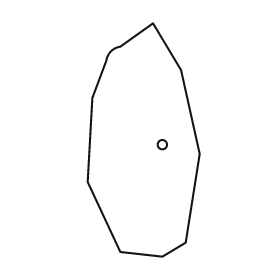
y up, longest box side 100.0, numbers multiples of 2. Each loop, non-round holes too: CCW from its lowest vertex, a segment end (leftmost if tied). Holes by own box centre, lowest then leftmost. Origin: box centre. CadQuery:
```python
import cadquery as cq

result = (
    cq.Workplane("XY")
    .moveTo(8.0, -50.0)
    .lineTo(18.0, -44.0)
    .lineTo(24.0, -6.0)
    .lineTo(16.0, 30.0)
    .lineTo(4.0, 50.0)
    .lineTo(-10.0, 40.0)
    .threePointArc((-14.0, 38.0), (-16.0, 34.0))
    .lineTo(-22.0, 18.0)
    .lineTo(-24.0, -18.0)
    .lineTo(-10.0, -48.0)
    .close()
    .moveTo(8.0, -2.0)
    .circle(2.0)
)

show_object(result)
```